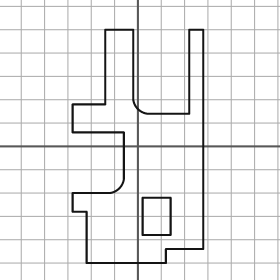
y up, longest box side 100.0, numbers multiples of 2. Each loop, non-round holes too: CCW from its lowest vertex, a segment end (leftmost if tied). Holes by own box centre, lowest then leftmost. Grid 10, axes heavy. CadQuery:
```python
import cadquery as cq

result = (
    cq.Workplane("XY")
    .moveTo(-22.0, -50.0)
    .lineTo(12.0, -50.0)
    .lineTo(12.0, -44.0)
    .lineTo(28.0, -44.0)
    .lineTo(28.0, 50.0)
    .lineTo(22.0, 50.0)
    .lineTo(22.0, 14.0)
    .lineTo(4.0, 14.0)
    .threePointArc((0.0, 16.0), (-2.0, 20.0))
    .lineTo(-2.0, 50.0)
    .lineTo(-14.0, 50.0)
    .lineTo(-14.0, 18.0)
    .lineTo(-28.0, 18.0)
    .lineTo(-28.0, 6.0)
    .lineTo(-6.0, 6.0)
    .lineTo(-6.0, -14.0)
    .threePointArc((-8.0, -18.0), (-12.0, -20.0))
    .lineTo(-28.0, -20.0)
    .lineTo(-28.0, -28.0)
    .lineTo(-22.0, -28.0)
    .close()
    .moveTo(2.0, -38.0)
    .lineTo(14.0, -38.0)
    .lineTo(14.0, -22.0)
    .lineTo(2.0, -22.0)
    .close()
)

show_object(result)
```